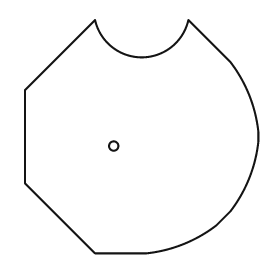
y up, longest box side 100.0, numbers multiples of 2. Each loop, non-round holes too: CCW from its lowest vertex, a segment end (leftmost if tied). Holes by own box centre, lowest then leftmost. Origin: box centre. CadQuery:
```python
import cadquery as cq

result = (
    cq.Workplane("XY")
    .moveTo(-20.0, -50.0)
    .lineTo(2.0, -50.0)
    .threePointArc((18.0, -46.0), (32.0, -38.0))
    .lineTo(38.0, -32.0)
    .threePointArc((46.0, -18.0), (50.0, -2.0))
    .lineTo(50.0, 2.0)
    .threePointArc((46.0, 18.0), (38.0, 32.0))
    .lineTo(20.0, 50.0)
    .threePointArc((0.0, 34.0), (-20.0, 50.0))
    .lineTo(-50.0, 20.0)
    .lineTo(-50.0, -20.0)
    .close()
    .moveTo(-12.0, -4.0)
    .circle(2.0)
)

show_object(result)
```